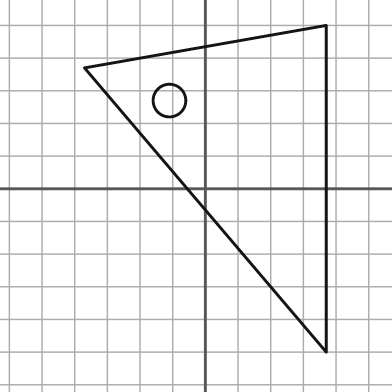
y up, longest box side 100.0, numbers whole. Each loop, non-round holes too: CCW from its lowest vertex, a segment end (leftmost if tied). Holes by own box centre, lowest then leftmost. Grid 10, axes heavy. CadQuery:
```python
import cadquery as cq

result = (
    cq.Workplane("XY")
    .moveTo(37.0, -50.0)
    .lineTo(37.0, 50.0)
    .lineTo(-37.0, 37.0)
    .close()
    .moveTo(-11.0, 27.0)
    .circle(5.0)
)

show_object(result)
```